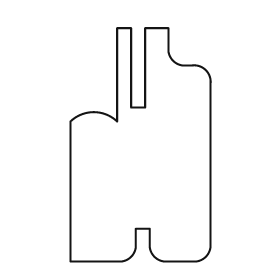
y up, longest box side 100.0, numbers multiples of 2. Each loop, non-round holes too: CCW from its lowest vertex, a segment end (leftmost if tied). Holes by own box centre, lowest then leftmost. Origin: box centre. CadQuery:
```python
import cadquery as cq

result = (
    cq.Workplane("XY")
    .moveTo(-30.0, -50.0)
    .lineTo(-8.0, -50.0)
    .threePointArc((-4.0, -48.0), (-2.0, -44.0))
    .lineTo(-2.0, -36.0)
    .lineTo(4.0, -36.0)
    .lineTo(4.0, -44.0)
    .threePointArc((6.0, -48.0), (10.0, -50.0))
    .lineTo(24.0, -50.0)
    .threePointArc((28.0, -48.0), (30.0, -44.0))
    .lineTo(30.0, 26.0)
    .threePointArc((28.0, 32.0), (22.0, 34.0))
    .lineTo(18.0, 34.0)
    .threePointArc((14.0, 36.0), (12.0, 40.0))
    .lineTo(12.0, 50.0)
    .lineTo(2.0, 50.0)
    .lineTo(2.0, 16.0)
    .lineTo(-4.0, 16.0)
    .lineTo(-4.0, 50.0)
    .lineTo(-10.0, 50.0)
    .lineTo(-10.0, 10.0)
    .threePointArc((-20.0, 14.0), (-30.0, 10.0))
    .close()
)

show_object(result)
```